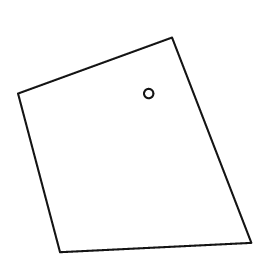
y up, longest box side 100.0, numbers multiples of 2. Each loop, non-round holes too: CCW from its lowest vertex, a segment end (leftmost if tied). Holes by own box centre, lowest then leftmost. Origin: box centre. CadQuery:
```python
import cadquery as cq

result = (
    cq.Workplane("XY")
    .moveTo(-32.0, -46.0)
    .lineTo(50.0, -42.0)
    .lineTo(16.0, 46.0)
    .lineTo(-50.0, 22.0)
    .close()
    .moveTo(6.0, 22.0)
    .circle(2.0)
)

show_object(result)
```